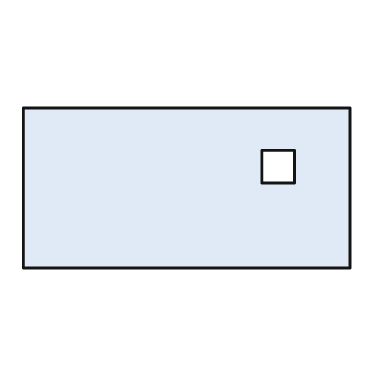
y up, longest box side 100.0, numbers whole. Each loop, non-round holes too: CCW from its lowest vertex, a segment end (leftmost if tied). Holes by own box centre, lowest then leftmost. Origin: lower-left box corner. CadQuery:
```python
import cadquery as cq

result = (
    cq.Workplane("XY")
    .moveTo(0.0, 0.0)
    .lineTo(100.0, 0.0)
    .lineTo(100.0, 49.0)
    .lineTo(0.0, 49.0)
    .close()
    .moveTo(73.0, 26.0)
    .lineTo(83.0, 26.0)
    .lineTo(83.0, 36.0)
    .lineTo(73.0, 36.0)
    .close()
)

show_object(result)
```